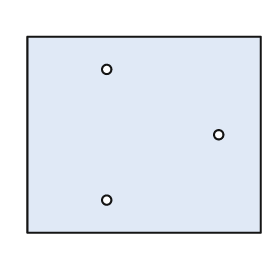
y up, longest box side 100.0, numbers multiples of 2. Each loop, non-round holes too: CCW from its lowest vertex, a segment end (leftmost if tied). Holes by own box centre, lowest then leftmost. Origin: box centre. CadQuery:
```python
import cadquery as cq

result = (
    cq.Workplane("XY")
    .moveTo(-50.0, -42.0)
    .lineTo(50.0, -42.0)
    .lineTo(50.0, 42.0)
    .lineTo(-50.0, 42.0)
    .close()
    .moveTo(-16.0, -28.0)
    .circle(2.0)
    .moveTo(32.0, 0.0)
    .circle(2.0)
    .moveTo(-16.0, 28.0)
    .circle(2.0)
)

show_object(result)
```